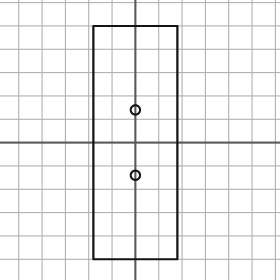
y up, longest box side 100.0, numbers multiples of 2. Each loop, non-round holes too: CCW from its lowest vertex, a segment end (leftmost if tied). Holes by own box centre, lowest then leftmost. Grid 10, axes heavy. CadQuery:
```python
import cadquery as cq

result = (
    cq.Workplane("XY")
    .moveTo(-18.0, -50.0)
    .lineTo(18.0, -50.0)
    .lineTo(18.0, 50.0)
    .lineTo(-18.0, 50.0)
    .close()
    .moveTo(0.0, -14.0)
    .circle(2.0)
    .moveTo(0.0, 14.0)
    .circle(2.0)
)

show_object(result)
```